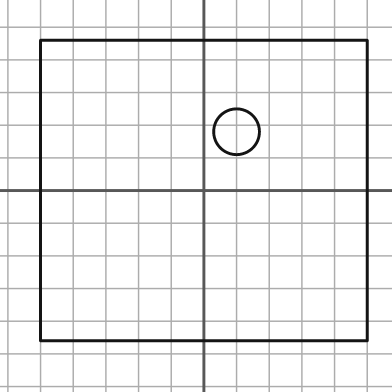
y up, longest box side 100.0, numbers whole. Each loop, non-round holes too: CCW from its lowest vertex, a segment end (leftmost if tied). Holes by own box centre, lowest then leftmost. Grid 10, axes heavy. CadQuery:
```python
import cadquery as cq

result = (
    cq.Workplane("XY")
    .moveTo(-50.0, -46.0)
    .lineTo(50.0, -46.0)
    .lineTo(50.0, 46.0)
    .lineTo(-50.0, 46.0)
    .close()
    .moveTo(10.0, 18.0)
    .circle(7.0)
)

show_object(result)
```